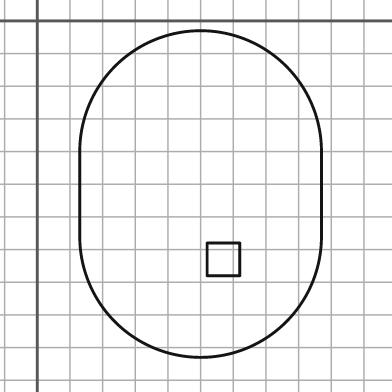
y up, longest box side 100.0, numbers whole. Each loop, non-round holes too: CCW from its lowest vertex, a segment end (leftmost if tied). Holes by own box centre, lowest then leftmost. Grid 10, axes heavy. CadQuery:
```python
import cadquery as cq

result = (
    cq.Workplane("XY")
    .moveTo(13.0, -66.0)
    .threePointArc((50.0, -103.0), (87.0, -66.0))
    .lineTo(87.0, -40.0)
    .threePointArc((50.0, -3.0), (13.0, -40.0))
    .close()
    .moveTo(52.0, -78.0)
    .lineTo(62.0, -78.0)
    .lineTo(62.0, -68.0)
    .lineTo(52.0, -68.0)
    .close()
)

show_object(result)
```